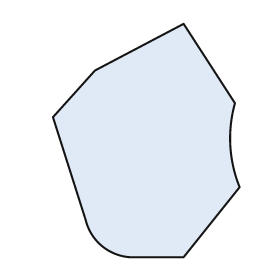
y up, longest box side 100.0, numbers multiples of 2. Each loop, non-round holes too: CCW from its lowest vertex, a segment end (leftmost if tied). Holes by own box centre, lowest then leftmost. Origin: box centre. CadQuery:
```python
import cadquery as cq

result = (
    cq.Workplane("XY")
    .moveTo(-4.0, -50.0)
    .lineTo(16.0, -50.0)
    .lineTo(40.0, -20.0)
    .threePointArc((36.0, -2.0), (38.0, 16.0))
    .lineTo(16.0, 50.0)
    .lineTo(-22.0, 30.0)
    .lineTo(-40.0, 10.0)
    .lineTo(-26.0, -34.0)
    .threePointArc((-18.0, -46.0), (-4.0, -50.0))
    .close()
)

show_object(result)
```